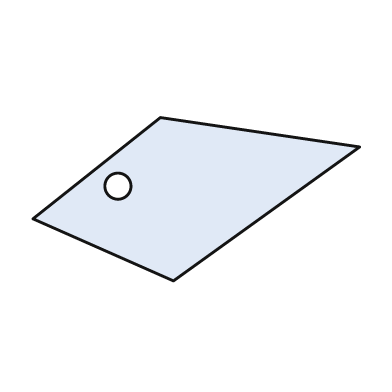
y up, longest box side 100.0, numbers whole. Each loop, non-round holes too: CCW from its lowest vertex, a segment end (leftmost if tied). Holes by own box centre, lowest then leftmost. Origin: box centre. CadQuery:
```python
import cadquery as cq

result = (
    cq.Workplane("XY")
    .moveTo(-7.0, -25.0)
    .lineTo(50.0, 16.0)
    .lineTo(-11.0, 25.0)
    .lineTo(-50.0, -6.0)
    .close()
    .moveTo(-24.0, 4.0)
    .circle(4.0)
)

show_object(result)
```